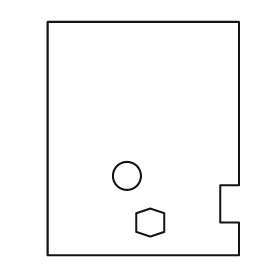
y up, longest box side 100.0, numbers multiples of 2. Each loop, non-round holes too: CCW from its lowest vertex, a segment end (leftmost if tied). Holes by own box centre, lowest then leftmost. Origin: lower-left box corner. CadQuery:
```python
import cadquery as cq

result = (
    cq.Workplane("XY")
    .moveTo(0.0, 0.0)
    .lineTo(82.0, 0.0)
    .lineTo(82.0, 14.0)
    .lineTo(74.0, 14.0)
    .lineTo(74.0, 30.0)
    .lineTo(82.0, 30.0)
    .lineTo(82.0, 100.0)
    .lineTo(0.0, 100.0)
    .close()
    .moveTo(44.0, 8.0)
    .lineTo(50.0, 10.0)
    .lineTo(50.0, 18.0)
    .lineTo(44.0, 20.0)
    .lineTo(38.0, 18.0)
    .lineTo(38.0, 10.0)
    .close()
    .moveTo(34.0, 34.0)
    .circle(6.0)
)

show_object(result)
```